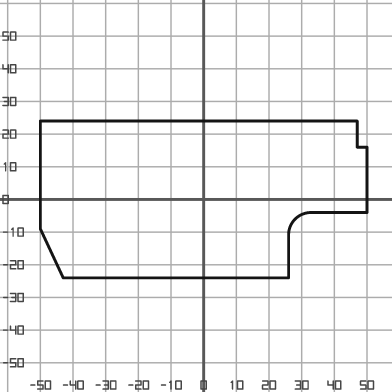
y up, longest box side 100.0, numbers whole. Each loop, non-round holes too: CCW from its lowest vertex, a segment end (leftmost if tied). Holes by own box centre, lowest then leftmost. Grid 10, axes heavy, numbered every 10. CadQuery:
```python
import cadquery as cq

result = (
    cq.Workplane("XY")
    .moveTo(-43.0, -24.0)
    .lineTo(26.0, -24.0)
    .lineTo(26.0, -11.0)
    .threePointArc((28.0, -6.0), (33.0, -4.0))
    .lineTo(50.0, -4.0)
    .lineTo(50.0, 16.0)
    .lineTo(47.0, 16.0)
    .lineTo(47.0, 24.0)
    .lineTo(-50.0, 24.0)
    .lineTo(-50.0, -9.0)
    .close()
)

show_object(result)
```